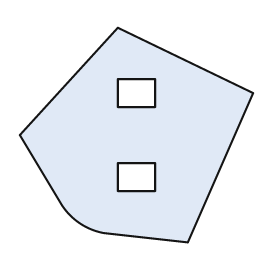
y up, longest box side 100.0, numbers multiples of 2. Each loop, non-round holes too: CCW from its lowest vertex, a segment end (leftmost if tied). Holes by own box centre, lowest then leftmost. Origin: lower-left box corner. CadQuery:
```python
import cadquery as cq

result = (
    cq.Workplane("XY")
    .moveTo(72.0, 0.0)
    .lineTo(100.0, 64.0)
    .lineTo(42.0, 92.0)
    .lineTo(0.0, 46.0)
    .lineTo(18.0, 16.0)
    .threePointArc((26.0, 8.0), (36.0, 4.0))
    .close()
    .moveTo(42.0, 22.0)
    .lineTo(58.0, 22.0)
    .lineTo(58.0, 34.0)
    .lineTo(42.0, 34.0)
    .close()
    .moveTo(42.0, 58.0)
    .lineTo(58.0, 58.0)
    .lineTo(58.0, 70.0)
    .lineTo(42.0, 70.0)
    .close()
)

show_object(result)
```